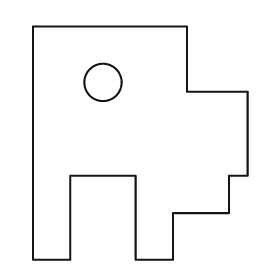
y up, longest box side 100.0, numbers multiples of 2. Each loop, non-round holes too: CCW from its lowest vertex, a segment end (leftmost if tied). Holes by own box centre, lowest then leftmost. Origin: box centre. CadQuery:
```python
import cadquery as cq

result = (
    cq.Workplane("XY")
    .moveTo(-46.0, -50.0)
    .lineTo(-30.0, -50.0)
    .lineTo(-30.0, -14.0)
    .lineTo(-2.0, -14.0)
    .lineTo(-2.0, -50.0)
    .lineTo(14.0, -50.0)
    .lineTo(14.0, -30.0)
    .lineTo(38.0, -30.0)
    .lineTo(38.0, -14.0)
    .lineTo(46.0, -14.0)
    .lineTo(46.0, 22.0)
    .lineTo(20.0, 22.0)
    .lineTo(20.0, 50.0)
    .lineTo(-46.0, 50.0)
    .close()
    .moveTo(-16.0, 26.0)
    .circle(8.0)
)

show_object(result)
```